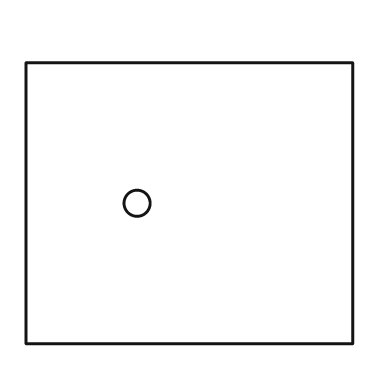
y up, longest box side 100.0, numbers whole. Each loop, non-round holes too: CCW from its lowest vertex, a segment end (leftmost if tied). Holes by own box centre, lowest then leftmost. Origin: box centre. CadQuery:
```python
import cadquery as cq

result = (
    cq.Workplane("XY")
    .moveTo(-50.0, -43.0)
    .lineTo(50.0, -43.0)
    .lineTo(50.0, 43.0)
    .lineTo(-50.0, 43.0)
    .close()
    .moveTo(-16.0, 0.0)
    .circle(4.0)
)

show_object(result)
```